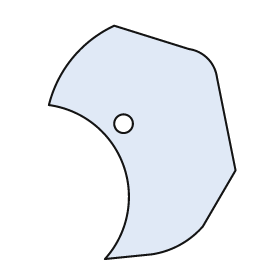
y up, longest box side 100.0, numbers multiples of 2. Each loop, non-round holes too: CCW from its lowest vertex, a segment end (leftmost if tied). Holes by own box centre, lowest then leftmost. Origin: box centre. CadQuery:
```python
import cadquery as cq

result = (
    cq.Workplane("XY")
    .moveTo(-16.0, -50.0)
    .lineTo(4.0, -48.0)
    .threePointArc((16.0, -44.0), (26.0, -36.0))
    .lineTo(40.0, -12.0)
    .lineTo(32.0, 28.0)
    .threePointArc((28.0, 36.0), (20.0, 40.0))
    .lineTo(-12.0, 50.0)
    .threePointArc((-30.0, 36.0), (-40.0, 16.0))
    .threePointArc((-8.0, -10.0), (-16.0, -50.0))
    .close()
    .moveTo(-8.0, 8.0)
    .circle(4.0)
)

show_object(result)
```